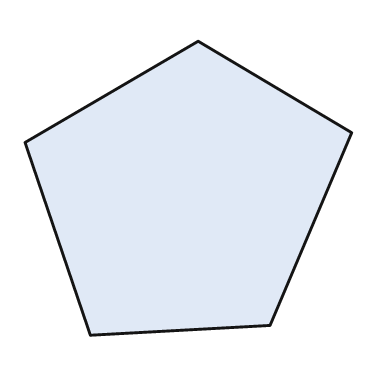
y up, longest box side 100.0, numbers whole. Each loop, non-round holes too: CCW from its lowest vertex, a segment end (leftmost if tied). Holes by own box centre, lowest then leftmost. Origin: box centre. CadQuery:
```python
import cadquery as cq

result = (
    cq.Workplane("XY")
    .moveTo(-30.0, -45.0)
    .lineTo(25.0, -42.0)
    .lineTo(50.0, 17.0)
    .lineTo(3.0, 45.0)
    .lineTo(-50.0, 14.0)
    .close()
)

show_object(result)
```